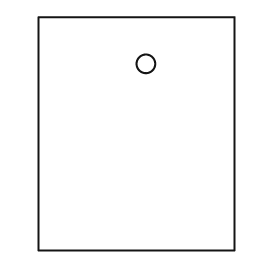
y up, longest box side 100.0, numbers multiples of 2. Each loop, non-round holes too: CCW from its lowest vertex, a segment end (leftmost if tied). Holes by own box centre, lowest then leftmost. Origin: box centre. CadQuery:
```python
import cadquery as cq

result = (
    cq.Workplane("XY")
    .moveTo(-42.0, -50.0)
    .lineTo(42.0, -50.0)
    .lineTo(42.0, 50.0)
    .lineTo(-42.0, 50.0)
    .close()
    .moveTo(4.0, 30.0)
    .circle(4.0)
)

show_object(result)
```